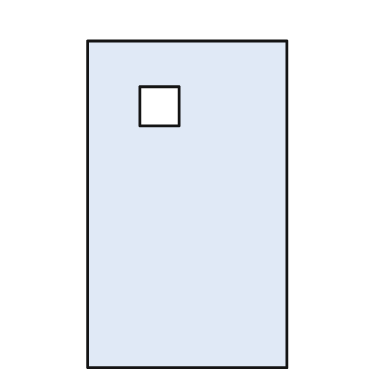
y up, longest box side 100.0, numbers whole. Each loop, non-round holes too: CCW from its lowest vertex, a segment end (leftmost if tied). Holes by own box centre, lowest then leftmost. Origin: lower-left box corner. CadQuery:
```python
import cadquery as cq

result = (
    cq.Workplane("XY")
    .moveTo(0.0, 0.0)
    .lineTo(61.0, 0.0)
    .lineTo(61.0, 100.0)
    .lineTo(0.0, 100.0)
    .close()
    .moveTo(16.0, 74.0)
    .lineTo(28.0, 74.0)
    .lineTo(28.0, 86.0)
    .lineTo(16.0, 86.0)
    .close()
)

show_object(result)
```